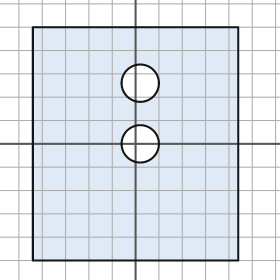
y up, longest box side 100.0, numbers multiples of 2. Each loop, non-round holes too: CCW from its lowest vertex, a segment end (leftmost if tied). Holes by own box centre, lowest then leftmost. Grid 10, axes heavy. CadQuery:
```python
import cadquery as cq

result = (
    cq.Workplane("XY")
    .moveTo(-44.0, -50.0)
    .lineTo(44.0, -50.0)
    .lineTo(44.0, 50.0)
    .lineTo(-44.0, 50.0)
    .close()
    .moveTo(2.0, 0.0)
    .circle(8.0)
    .moveTo(2.0, 26.0)
    .circle(8.0)
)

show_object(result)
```